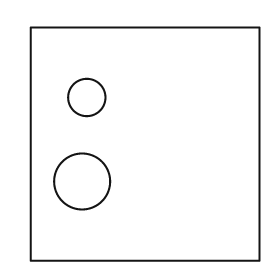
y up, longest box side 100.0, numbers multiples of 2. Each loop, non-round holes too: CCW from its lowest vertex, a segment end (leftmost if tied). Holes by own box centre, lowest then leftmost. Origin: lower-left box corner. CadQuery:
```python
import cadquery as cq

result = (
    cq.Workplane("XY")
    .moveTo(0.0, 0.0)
    .lineTo(98.0, 0.0)
    .lineTo(98.0, 100.0)
    .lineTo(0.0, 100.0)
    .close()
    .moveTo(22.0, 34.0)
    .circle(12.0)
    .moveTo(24.0, 70.0)
    .circle(8.0)
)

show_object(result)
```